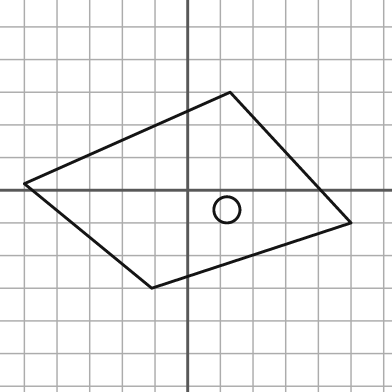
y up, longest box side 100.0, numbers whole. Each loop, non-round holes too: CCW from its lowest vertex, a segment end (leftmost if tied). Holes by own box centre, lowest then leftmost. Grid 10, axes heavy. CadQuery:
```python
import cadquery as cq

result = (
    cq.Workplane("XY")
    .moveTo(-11.0, -30.0)
    .lineTo(50.0, -10.0)
    .lineTo(13.0, 30.0)
    .lineTo(-50.0, 2.0)
    .close()
    .moveTo(12.0, -6.0)
    .circle(4.0)
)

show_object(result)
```